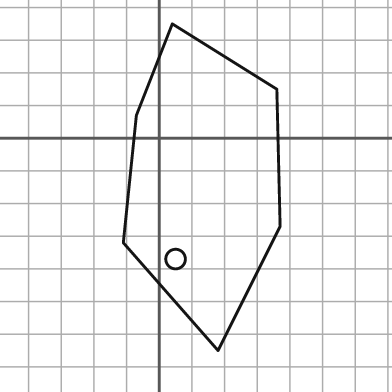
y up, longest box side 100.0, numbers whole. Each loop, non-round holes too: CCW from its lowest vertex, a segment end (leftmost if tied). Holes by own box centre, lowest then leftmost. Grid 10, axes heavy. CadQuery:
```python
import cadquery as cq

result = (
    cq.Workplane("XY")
    .moveTo(18.0, -65.0)
    .lineTo(37.0, -27.0)
    .lineTo(36.0, 15.0)
    .lineTo(4.0, 35.0)
    .lineTo(-7.0, 7.0)
    .lineTo(-11.0, -32.0)
    .close()
    .moveTo(5.0, -37.0)
    .circle(3.0)
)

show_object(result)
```